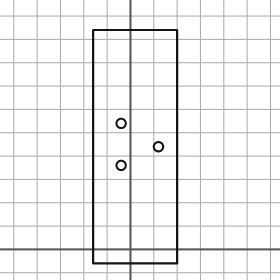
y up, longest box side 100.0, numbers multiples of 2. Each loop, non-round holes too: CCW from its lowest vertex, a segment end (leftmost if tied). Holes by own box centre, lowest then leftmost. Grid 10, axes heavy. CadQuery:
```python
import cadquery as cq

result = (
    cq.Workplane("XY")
    .moveTo(-16.0, -6.0)
    .lineTo(20.0, -6.0)
    .lineTo(20.0, 94.0)
    .lineTo(-16.0, 94.0)
    .close()
    .moveTo(-4.0, 36.0)
    .circle(2.0)
    .moveTo(12.0, 44.0)
    .circle(2.0)
    .moveTo(-4.0, 54.0)
    .circle(2.0)
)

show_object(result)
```